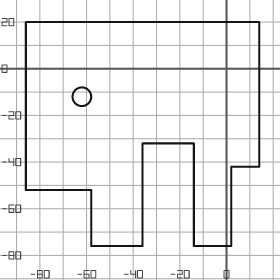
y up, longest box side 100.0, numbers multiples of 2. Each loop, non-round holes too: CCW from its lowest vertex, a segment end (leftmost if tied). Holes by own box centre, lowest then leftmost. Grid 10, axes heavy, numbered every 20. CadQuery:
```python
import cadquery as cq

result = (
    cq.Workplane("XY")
    .moveTo(-58.0, -76.0)
    .lineTo(-36.0, -76.0)
    .lineTo(-36.0, -32.0)
    .lineTo(-14.0, -32.0)
    .lineTo(-14.0, -76.0)
    .lineTo(2.0, -76.0)
    .lineTo(2.0, -42.0)
    .lineTo(14.0, -42.0)
    .lineTo(14.0, 20.0)
    .lineTo(-86.0, 20.0)
    .lineTo(-86.0, -52.0)
    .lineTo(-58.0, -52.0)
    .close()
    .moveTo(-62.0, -12.0)
    .circle(4.0)
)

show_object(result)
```